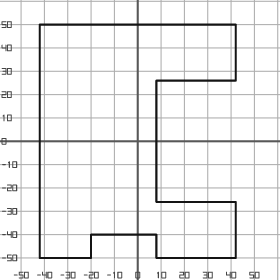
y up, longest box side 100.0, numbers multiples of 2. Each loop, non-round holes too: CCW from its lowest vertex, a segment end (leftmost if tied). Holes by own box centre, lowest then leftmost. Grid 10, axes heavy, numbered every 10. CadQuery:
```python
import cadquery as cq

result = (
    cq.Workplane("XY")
    .moveTo(-42.0, -50.0)
    .lineTo(-20.0, -50.0)
    .lineTo(-20.0, -40.0)
    .lineTo(8.0, -40.0)
    .lineTo(8.0, -50.0)
    .lineTo(42.0, -50.0)
    .lineTo(42.0, -26.0)
    .lineTo(8.0, -26.0)
    .lineTo(8.0, 26.0)
    .lineTo(42.0, 26.0)
    .lineTo(42.0, 50.0)
    .lineTo(-42.0, 50.0)
    .close()
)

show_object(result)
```